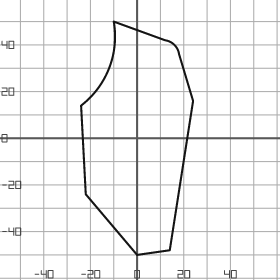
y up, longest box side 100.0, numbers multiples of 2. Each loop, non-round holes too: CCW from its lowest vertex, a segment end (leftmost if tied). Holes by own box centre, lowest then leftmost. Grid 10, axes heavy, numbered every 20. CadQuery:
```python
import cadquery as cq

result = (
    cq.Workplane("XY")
    .moveTo(0.0, -50.0)
    .lineTo(14.0, -48.0)
    .lineTo(24.0, 16.0)
    .lineTo(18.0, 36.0)
    .threePointArc((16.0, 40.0), (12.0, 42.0))
    .lineTo(-10.0, 50.0)
    .threePointArc((-12.0, 30.0), (-24.0, 14.0))
    .lineTo(-22.0, -24.0)
    .close()
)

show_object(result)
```